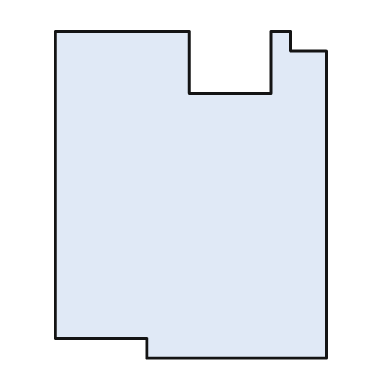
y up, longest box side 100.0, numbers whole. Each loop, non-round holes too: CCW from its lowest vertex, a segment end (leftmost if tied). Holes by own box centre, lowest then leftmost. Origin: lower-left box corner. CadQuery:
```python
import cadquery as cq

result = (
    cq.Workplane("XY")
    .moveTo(28.0, 0.0)
    .lineTo(83.0, 0.0)
    .lineTo(83.0, 94.0)
    .lineTo(72.0, 94.0)
    .lineTo(72.0, 100.0)
    .lineTo(66.0, 100.0)
    .lineTo(66.0, 81.0)
    .lineTo(41.0, 81.0)
    .lineTo(41.0, 100.0)
    .lineTo(0.0, 100.0)
    .lineTo(0.0, 6.0)
    .lineTo(28.0, 6.0)
    .close()
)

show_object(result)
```